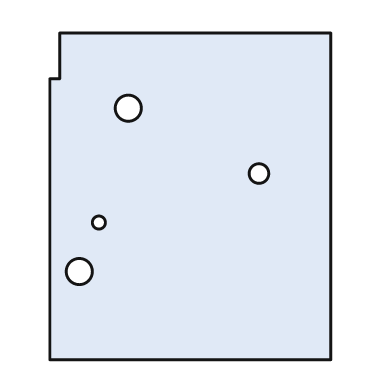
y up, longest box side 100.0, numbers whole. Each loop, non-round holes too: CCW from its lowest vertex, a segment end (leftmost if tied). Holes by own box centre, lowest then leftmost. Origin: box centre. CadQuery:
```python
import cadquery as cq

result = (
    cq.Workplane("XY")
    .moveTo(-43.0, -50.0)
    .lineTo(43.0, -50.0)
    .lineTo(43.0, 50.0)
    .lineTo(-40.0, 50.0)
    .lineTo(-40.0, 36.0)
    .lineTo(-43.0, 36.0)
    .close()
    .moveTo(-34.0, -23.0)
    .circle(4.0)
    .moveTo(-28.0, -8.0)
    .circle(2.0)
    .moveTo(21.0, 7.0)
    .circle(3.0)
    .moveTo(-19.0, 27.0)
    .circle(4.0)
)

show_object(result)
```